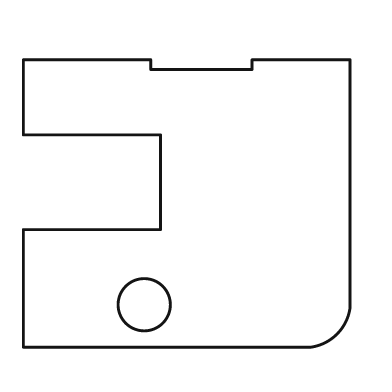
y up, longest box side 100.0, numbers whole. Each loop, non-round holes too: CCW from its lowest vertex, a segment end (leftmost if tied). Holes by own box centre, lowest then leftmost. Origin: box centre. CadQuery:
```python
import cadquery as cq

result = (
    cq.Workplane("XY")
    .moveTo(-50.0, -44.0)
    .lineTo(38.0, -44.0)
    .threePointArc((46.0, -40.0), (50.0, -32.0))
    .lineTo(50.0, 44.0)
    .lineTo(20.0, 44.0)
    .lineTo(20.0, 41.0)
    .lineTo(-11.0, 41.0)
    .lineTo(-11.0, 44.0)
    .lineTo(-50.0, 44.0)
    .lineTo(-50.0, 21.0)
    .lineTo(-8.0, 21.0)
    .lineTo(-8.0, -8.0)
    .lineTo(-50.0, -8.0)
    .close()
    .moveTo(-13.0, -31.0)
    .circle(8.0)
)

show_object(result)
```